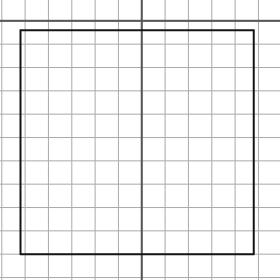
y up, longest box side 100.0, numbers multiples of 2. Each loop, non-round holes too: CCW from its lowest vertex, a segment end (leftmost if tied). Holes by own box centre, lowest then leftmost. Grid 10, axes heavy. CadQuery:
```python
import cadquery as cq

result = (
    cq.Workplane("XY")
    .moveTo(-52.0, -100.0)
    .lineTo(48.0, -100.0)
    .lineTo(48.0, -4.0)
    .lineTo(-52.0, -4.0)
    .close()
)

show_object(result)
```